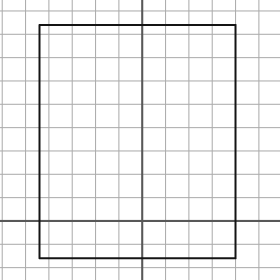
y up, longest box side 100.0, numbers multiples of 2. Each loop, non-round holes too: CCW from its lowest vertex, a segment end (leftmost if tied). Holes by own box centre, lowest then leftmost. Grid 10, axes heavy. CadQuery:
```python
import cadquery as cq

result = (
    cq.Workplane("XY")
    .moveTo(-44.0, -16.0)
    .lineTo(40.0, -16.0)
    .lineTo(40.0, 84.0)
    .lineTo(-44.0, 84.0)
    .close()
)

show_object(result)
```